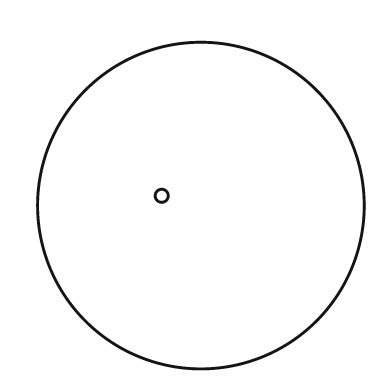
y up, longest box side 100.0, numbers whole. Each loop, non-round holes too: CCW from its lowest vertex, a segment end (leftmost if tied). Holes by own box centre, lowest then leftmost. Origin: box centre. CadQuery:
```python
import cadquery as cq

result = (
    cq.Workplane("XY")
    .moveTo(0.0, 0.0)
    .circle(50.0)
    .moveTo(-12.0, 3.0)
    .circle(2.0)
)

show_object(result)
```